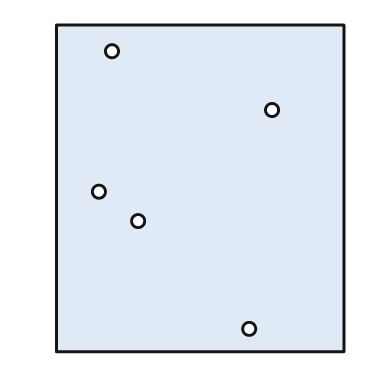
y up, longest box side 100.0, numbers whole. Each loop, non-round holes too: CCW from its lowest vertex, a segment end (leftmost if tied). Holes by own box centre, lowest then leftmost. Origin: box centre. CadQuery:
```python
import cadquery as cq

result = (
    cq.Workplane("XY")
    .moveTo(-44.0, -50.0)
    .lineTo(44.0, -50.0)
    .lineTo(44.0, 50.0)
    .lineTo(-44.0, 50.0)
    .close()
    .moveTo(15.0, -43.0)
    .circle(2.0)
    .moveTo(-19.0, -10.0)
    .circle(2.0)
    .moveTo(-31.0, -1.0)
    .circle(2.0)
    .moveTo(22.0, 24.0)
    .circle(2.0)
    .moveTo(-27.0, 42.0)
    .circle(2.0)
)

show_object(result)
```